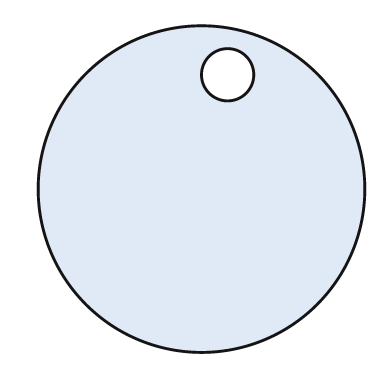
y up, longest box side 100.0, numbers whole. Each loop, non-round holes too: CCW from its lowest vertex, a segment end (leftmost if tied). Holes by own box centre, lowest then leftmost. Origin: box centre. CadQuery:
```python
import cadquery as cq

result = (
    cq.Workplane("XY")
    .moveTo(0.0, 0.0)
    .circle(50.0)
    .moveTo(8.0, 35.0)
    .circle(8.0)
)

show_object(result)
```